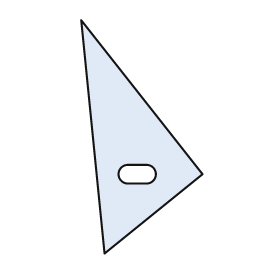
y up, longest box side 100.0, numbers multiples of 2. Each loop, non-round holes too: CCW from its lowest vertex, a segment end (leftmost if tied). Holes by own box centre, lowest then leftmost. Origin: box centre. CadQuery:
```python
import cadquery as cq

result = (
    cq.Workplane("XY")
    .moveTo(-16.0, -50.0)
    .lineTo(26.0, -16.0)
    .lineTo(-26.0, 50.0)
    .close()
    .moveTo(-6.0, -20.0)
    .lineTo(2.0, -20.0)
    .threePointArc((6.0, -16.0), (2.0, -12.0))
    .lineTo(-6.0, -12.0)
    .threePointArc((-10.0, -16.0), (-6.0, -20.0))
    .close()
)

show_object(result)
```